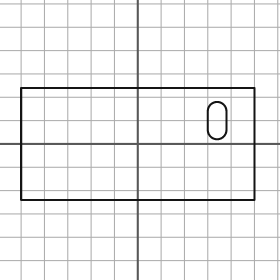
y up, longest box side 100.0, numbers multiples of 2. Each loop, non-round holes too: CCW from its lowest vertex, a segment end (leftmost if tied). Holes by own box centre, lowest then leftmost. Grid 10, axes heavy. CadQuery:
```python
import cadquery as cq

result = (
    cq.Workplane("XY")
    .moveTo(-50.0, -24.0)
    .lineTo(50.0, -24.0)
    .lineTo(50.0, 24.0)
    .lineTo(-50.0, 24.0)
    .close()
    .moveTo(30.0, 6.0)
    .threePointArc((34.0, 2.0), (38.0, 6.0))
    .lineTo(38.0, 14.0)
    .threePointArc((34.0, 18.0), (30.0, 14.0))
    .close()
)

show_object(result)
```